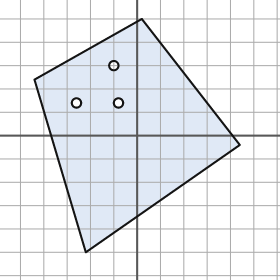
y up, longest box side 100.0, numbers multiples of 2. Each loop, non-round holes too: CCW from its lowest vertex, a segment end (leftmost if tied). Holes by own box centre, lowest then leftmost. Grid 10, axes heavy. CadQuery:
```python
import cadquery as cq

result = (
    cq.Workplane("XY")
    .moveTo(-22.0, -50.0)
    .lineTo(44.0, -4.0)
    .lineTo(2.0, 50.0)
    .lineTo(-44.0, 24.0)
    .close()
    .moveTo(-26.0, 14.0)
    .circle(2.0)
    .moveTo(-8.0, 14.0)
    .circle(2.0)
    .moveTo(-10.0, 30.0)
    .circle(2.0)
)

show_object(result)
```